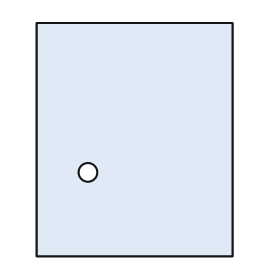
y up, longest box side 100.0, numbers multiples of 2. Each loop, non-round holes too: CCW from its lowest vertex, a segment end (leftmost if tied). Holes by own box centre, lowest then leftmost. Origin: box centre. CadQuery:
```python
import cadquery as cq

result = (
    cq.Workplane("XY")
    .moveTo(-42.0, -50.0)
    .lineTo(42.0, -50.0)
    .lineTo(42.0, 50.0)
    .lineTo(-42.0, 50.0)
    .close()
    .moveTo(-20.0, -14.0)
    .circle(4.0)
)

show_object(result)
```